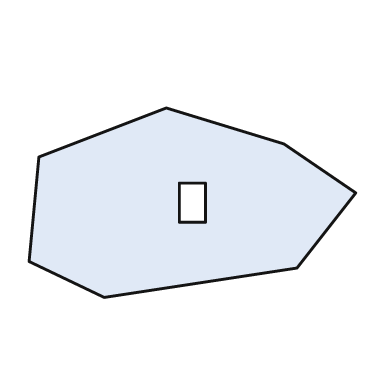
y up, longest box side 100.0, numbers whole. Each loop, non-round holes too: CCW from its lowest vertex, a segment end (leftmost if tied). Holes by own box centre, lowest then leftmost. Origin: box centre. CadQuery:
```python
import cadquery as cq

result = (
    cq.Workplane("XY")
    .moveTo(-27.0, -29.0)
    .lineTo(32.0, -20.0)
    .lineTo(50.0, 3.0)
    .lineTo(28.0, 18.0)
    .lineTo(-8.0, 29.0)
    .lineTo(-47.0, 14.0)
    .lineTo(-50.0, -18.0)
    .close()
    .moveTo(-4.0, -6.0)
    .lineTo(4.0, -6.0)
    .lineTo(4.0, 6.0)
    .lineTo(-4.0, 6.0)
    .close()
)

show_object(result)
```